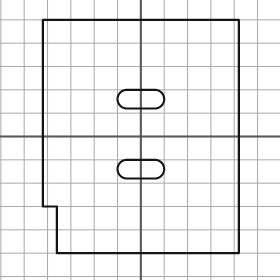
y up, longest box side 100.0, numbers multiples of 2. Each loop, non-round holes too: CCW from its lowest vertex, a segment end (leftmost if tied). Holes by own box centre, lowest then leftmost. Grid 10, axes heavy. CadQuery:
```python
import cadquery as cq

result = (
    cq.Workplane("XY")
    .moveTo(-36.0, -50.0)
    .lineTo(42.0, -50.0)
    .lineTo(42.0, 50.0)
    .lineTo(-42.0, 50.0)
    .lineTo(-42.0, -30.0)
    .lineTo(-36.0, -30.0)
    .close()
    .moveTo(-6.0, -18.0)
    .lineTo(6.0, -18.0)
    .threePointArc((10.0, -14.0), (6.0, -10.0))
    .lineTo(-6.0, -10.0)
    .threePointArc((-10.0, -14.0), (-6.0, -18.0))
    .close()
    .moveTo(-6.0, 12.0)
    .lineTo(6.0, 12.0)
    .threePointArc((10.0, 16.0), (6.0, 20.0))
    .lineTo(-6.0, 20.0)
    .threePointArc((-10.0, 16.0), (-6.0, 12.0))
    .close()
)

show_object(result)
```